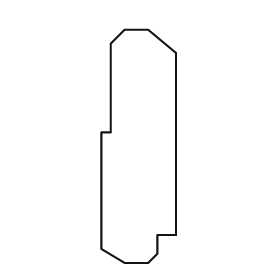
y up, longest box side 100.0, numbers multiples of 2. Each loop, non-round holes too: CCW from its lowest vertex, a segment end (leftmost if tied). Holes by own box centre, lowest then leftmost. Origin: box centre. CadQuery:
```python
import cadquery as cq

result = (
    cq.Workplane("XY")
    .moveTo(-6.0, -50.0)
    .lineTo(4.0, -50.0)
    .lineTo(8.0, -46.0)
    .lineTo(8.0, -38.0)
    .lineTo(16.0, -38.0)
    .lineTo(16.0, 40.0)
    .lineTo(4.0, 50.0)
    .lineTo(-6.0, 50.0)
    .lineTo(-12.0, 44.0)
    .lineTo(-12.0, 6.0)
    .lineTo(-16.0, 6.0)
    .lineTo(-16.0, -44.0)
    .close()
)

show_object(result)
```